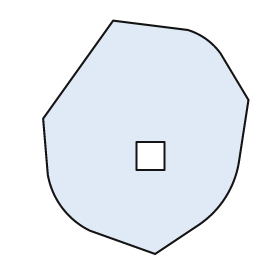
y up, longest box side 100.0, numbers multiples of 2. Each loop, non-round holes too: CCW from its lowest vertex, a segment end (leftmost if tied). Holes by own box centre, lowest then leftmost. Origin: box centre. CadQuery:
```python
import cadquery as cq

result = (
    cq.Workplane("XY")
    .moveTo(4.0, -50.0)
    .lineTo(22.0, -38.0)
    .threePointArc((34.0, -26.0), (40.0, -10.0))
    .lineTo(44.0, 16.0)
    .lineTo(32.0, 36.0)
    .threePointArc((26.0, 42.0), (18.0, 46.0))
    .lineTo(-14.0, 50.0)
    .lineTo(-44.0, 8.0)
    .lineTo(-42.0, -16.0)
    .threePointArc((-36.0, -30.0), (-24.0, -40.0))
    .close()
    .moveTo(-4.0, -14.0)
    .lineTo(8.0, -14.0)
    .lineTo(8.0, -2.0)
    .lineTo(-4.0, -2.0)
    .close()
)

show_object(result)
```